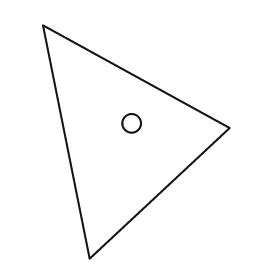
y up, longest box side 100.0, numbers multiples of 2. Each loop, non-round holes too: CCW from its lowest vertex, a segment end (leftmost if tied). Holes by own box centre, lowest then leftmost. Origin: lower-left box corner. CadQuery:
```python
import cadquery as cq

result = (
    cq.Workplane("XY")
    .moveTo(20.0, 0.0)
    .lineTo(80.0, 56.0)
    .lineTo(0.0, 100.0)
    .close()
    .moveTo(38.0, 58.0)
    .circle(4.0)
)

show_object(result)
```